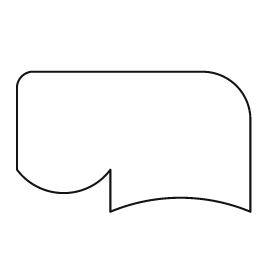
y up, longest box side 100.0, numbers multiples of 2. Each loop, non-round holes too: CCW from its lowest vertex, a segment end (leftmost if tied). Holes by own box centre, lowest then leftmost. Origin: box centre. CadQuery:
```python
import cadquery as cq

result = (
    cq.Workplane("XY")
    .moveTo(-10.0, -30.0)
    .threePointArc((20.0, -24.0), (50.0, -30.0))
    .lineTo(50.0, 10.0)
    .threePointArc((44.0, 24.0), (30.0, 30.0))
    .lineTo(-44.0, 30.0)
    .threePointArc((-48.0, 28.0), (-50.0, 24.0))
    .lineTo(-50.0, -12.0)
    .threePointArc((-30.0, -22.0), (-10.0, -12.0))
    .close()
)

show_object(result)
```